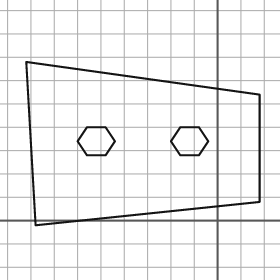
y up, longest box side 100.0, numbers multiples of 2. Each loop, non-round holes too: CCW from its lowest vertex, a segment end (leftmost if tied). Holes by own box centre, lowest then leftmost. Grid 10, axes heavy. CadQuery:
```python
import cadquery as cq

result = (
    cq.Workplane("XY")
    .moveTo(-78.0, -2.0)
    .lineTo(18.0, 8.0)
    .lineTo(18.0, 54.0)
    .lineTo(-82.0, 68.0)
    .close()
    .moveTo(-56.0, 28.0)
    .lineTo(-48.0, 28.0)
    .lineTo(-44.0, 34.0)
    .lineTo(-48.0, 40.0)
    .lineTo(-56.0, 40.0)
    .lineTo(-60.0, 34.0)
    .close()
    .moveTo(-16.0, 28.0)
    .lineTo(-8.0, 28.0)
    .lineTo(-4.0, 34.0)
    .lineTo(-8.0, 40.0)
    .lineTo(-16.0, 40.0)
    .lineTo(-20.0, 34.0)
    .close()
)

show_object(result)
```